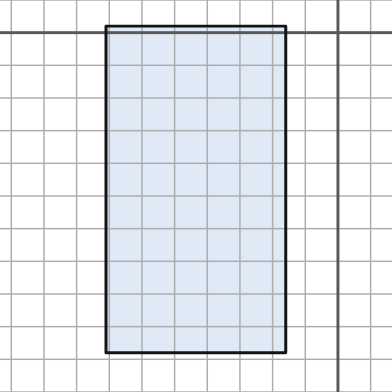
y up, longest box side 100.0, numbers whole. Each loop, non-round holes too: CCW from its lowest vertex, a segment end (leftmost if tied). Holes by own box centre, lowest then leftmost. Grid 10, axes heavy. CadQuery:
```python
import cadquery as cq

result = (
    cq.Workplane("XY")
    .moveTo(-71.0, -98.0)
    .lineTo(-16.0, -98.0)
    .lineTo(-16.0, 2.0)
    .lineTo(-71.0, 2.0)
    .close()
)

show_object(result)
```